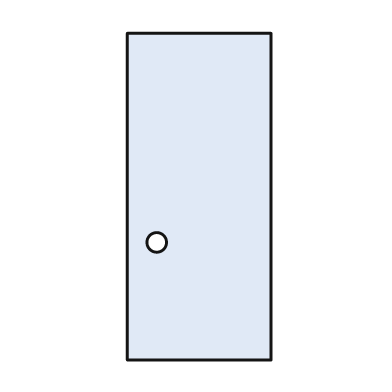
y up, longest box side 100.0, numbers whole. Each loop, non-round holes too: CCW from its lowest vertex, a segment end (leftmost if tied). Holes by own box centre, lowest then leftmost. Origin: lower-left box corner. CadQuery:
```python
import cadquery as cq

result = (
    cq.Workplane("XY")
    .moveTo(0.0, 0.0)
    .lineTo(44.0, 0.0)
    .lineTo(44.0, 100.0)
    .lineTo(0.0, 100.0)
    .close()
    .moveTo(9.0, 36.0)
    .circle(3.0)
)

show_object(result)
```